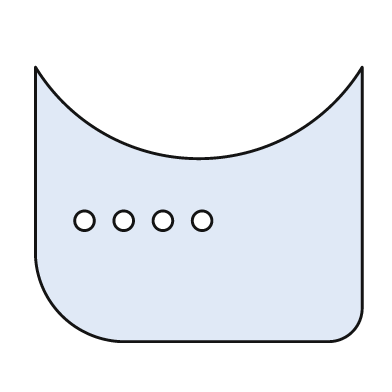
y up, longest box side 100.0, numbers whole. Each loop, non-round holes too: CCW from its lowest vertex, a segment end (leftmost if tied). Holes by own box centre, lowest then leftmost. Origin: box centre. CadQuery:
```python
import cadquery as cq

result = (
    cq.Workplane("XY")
    .moveTo(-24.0, -42.0)
    .lineTo(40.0, -42.0)
    .threePointArc((47.0, -39.0), (50.0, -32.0))
    .lineTo(50.0, 42.0)
    .threePointArc((0.0, 14.0), (-50.0, 42.0))
    .lineTo(-50.0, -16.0)
    .threePointArc((-42.0, -34.0), (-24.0, -42.0))
    .close()
    .moveTo(-35.0, -5.0)
    .circle(3.0)
    .moveTo(-23.0, -5.0)
    .circle(3.0)
    .moveTo(-11.0, -5.0)
    .circle(3.0)
    .moveTo(1.0, -5.0)
    .circle(3.0)
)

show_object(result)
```